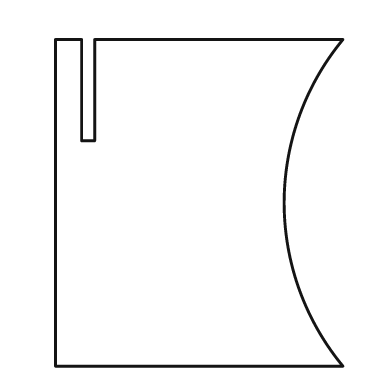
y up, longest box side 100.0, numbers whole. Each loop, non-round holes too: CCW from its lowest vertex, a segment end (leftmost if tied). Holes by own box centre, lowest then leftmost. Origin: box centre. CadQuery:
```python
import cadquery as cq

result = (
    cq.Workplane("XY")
    .moveTo(-44.0, -50.0)
    .lineTo(44.0, -50.0)
    .threePointArc((26.0, 0.0), (44.0, 50.0))
    .lineTo(-32.0, 50.0)
    .lineTo(-32.0, 19.0)
    .lineTo(-36.0, 19.0)
    .lineTo(-36.0, 50.0)
    .lineTo(-44.0, 50.0)
    .close()
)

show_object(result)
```